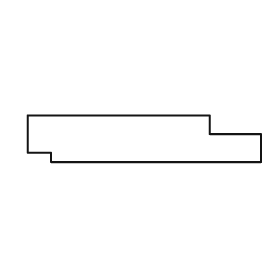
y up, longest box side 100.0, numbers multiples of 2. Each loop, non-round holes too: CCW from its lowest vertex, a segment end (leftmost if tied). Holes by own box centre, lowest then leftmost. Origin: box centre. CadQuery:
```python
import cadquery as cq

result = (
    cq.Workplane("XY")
    .moveTo(-40.0, -10.0)
    .lineTo(50.0, -10.0)
    .lineTo(50.0, 2.0)
    .lineTo(28.0, 2.0)
    .lineTo(28.0, 10.0)
    .lineTo(-50.0, 10.0)
    .lineTo(-50.0, -6.0)
    .lineTo(-40.0, -6.0)
    .close()
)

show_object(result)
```